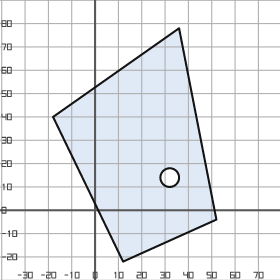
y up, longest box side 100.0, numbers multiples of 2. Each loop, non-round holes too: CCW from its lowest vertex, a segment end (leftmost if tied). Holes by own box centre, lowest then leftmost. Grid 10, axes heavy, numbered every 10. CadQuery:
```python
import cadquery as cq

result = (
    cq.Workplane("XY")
    .moveTo(12.0, -22.0)
    .lineTo(52.0, -4.0)
    .lineTo(36.0, 78.0)
    .lineTo(-18.0, 40.0)
    .close()
    .moveTo(32.0, 14.0)
    .circle(4.0)
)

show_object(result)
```